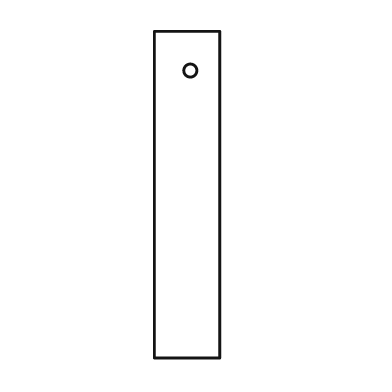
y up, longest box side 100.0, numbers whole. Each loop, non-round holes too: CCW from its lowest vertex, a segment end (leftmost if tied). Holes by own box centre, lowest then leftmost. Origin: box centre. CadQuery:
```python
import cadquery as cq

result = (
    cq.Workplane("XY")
    .moveTo(-10.0, -50.0)
    .lineTo(10.0, -50.0)
    .lineTo(10.0, 50.0)
    .lineTo(-10.0, 50.0)
    .close()
    .moveTo(1.0, 38.0)
    .circle(2.0)
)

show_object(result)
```